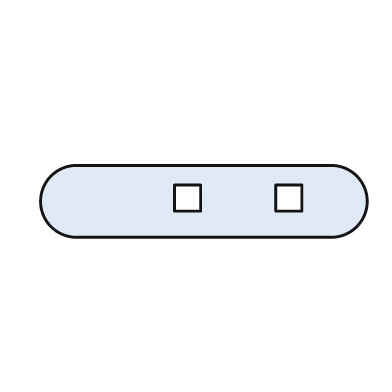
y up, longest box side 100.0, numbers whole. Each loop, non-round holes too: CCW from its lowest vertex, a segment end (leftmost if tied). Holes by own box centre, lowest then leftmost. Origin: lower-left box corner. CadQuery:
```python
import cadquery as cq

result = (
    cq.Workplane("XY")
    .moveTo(11.0, 0.0)
    .lineTo(89.0, 0.0)
    .threePointArc((100.0, 11.0), (89.0, 22.0))
    .lineTo(11.0, 22.0)
    .threePointArc((0.0, 11.0), (11.0, 0.0))
    .close()
    .moveTo(41.0, 8.0)
    .lineTo(49.0, 8.0)
    .lineTo(49.0, 16.0)
    .lineTo(41.0, 16.0)
    .close()
    .moveTo(72.0, 8.0)
    .lineTo(80.0, 8.0)
    .lineTo(80.0, 16.0)
    .lineTo(72.0, 16.0)
    .close()
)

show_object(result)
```